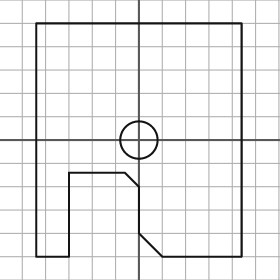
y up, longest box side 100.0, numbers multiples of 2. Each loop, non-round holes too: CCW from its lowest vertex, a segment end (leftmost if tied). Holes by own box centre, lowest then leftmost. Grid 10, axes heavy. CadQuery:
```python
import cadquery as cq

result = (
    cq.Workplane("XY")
    .moveTo(-44.0, -50.0)
    .lineTo(-30.0, -50.0)
    .lineTo(-30.0, -14.0)
    .lineTo(-6.0, -14.0)
    .lineTo(0.0, -20.0)
    .lineTo(0.0, -40.0)
    .lineTo(10.0, -50.0)
    .lineTo(44.0, -50.0)
    .lineTo(44.0, 50.0)
    .lineTo(-44.0, 50.0)
    .close()
    .moveTo(0.0, 0.0)
    .circle(8.0)
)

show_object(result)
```